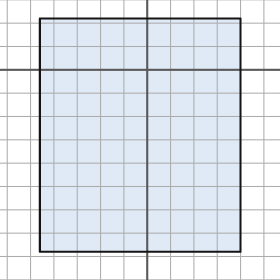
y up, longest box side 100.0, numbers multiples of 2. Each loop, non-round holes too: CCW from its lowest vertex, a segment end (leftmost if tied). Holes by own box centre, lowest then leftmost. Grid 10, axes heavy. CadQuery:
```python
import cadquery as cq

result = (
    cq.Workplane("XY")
    .moveTo(-46.0, -78.0)
    .lineTo(40.0, -78.0)
    .lineTo(40.0, 22.0)
    .lineTo(-46.0, 22.0)
    .close()
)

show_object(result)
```